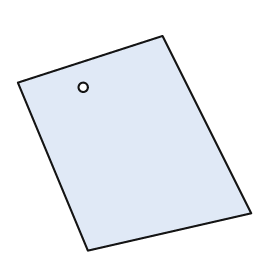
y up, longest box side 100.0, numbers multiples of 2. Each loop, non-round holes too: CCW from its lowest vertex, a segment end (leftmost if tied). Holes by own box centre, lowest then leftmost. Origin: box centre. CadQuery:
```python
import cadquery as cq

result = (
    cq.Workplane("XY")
    .moveTo(-20.0, -46.0)
    .lineTo(50.0, -30.0)
    .lineTo(12.0, 46.0)
    .lineTo(-50.0, 26.0)
    .close()
    .moveTo(-22.0, 24.0)
    .circle(2.0)
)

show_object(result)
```